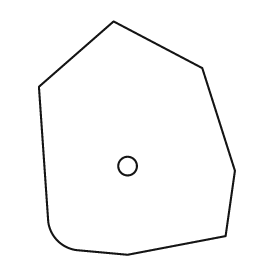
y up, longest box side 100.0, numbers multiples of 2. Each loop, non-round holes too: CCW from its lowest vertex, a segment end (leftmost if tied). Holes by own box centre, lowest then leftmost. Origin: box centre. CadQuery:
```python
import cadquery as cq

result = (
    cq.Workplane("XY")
    .moveTo(-4.0, -50.0)
    .lineTo(38.0, -42.0)
    .lineTo(42.0, -14.0)
    .lineTo(28.0, 30.0)
    .lineTo(-10.0, 50.0)
    .lineTo(-42.0, 22.0)
    .lineTo(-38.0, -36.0)
    .threePointArc((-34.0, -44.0), (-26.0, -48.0))
    .close()
    .moveTo(-4.0, -12.0)
    .circle(4.0)
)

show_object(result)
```